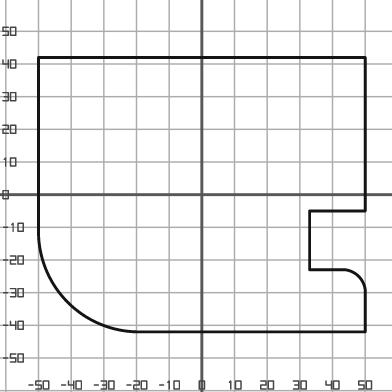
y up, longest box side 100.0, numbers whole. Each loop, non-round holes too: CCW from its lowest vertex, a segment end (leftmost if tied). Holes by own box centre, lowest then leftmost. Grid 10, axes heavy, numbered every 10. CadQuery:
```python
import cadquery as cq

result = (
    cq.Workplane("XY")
    .moveTo(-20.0, -42.0)
    .lineTo(50.0, -42.0)
    .lineTo(50.0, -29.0)
    .threePointArc((48.0, -25.0), (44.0, -23.0))
    .lineTo(33.0, -23.0)
    .lineTo(33.0, -5.0)
    .lineTo(50.0, -5.0)
    .lineTo(50.0, 42.0)
    .lineTo(-50.0, 42.0)
    .lineTo(-50.0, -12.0)
    .threePointArc((-41.0, -33.0), (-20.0, -42.0))
    .close()
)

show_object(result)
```